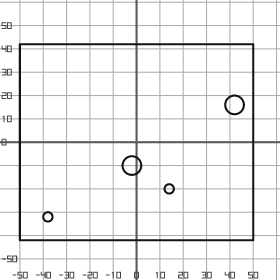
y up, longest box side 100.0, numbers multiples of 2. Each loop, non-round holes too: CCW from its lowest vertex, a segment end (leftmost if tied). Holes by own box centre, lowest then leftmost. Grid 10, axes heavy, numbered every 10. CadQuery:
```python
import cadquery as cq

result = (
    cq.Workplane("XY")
    .moveTo(-50.0, -42.0)
    .lineTo(50.0, -42.0)
    .lineTo(50.0, 42.0)
    .lineTo(-50.0, 42.0)
    .close()
    .moveTo(-38.0, -32.0)
    .circle(2.0)
    .moveTo(14.0, -20.0)
    .circle(2.0)
    .moveTo(-2.0, -10.0)
    .circle(4.0)
    .moveTo(42.0, 16.0)
    .circle(4.0)
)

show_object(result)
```